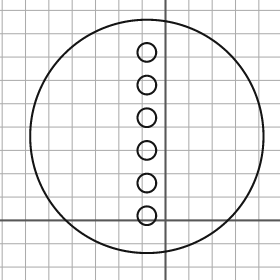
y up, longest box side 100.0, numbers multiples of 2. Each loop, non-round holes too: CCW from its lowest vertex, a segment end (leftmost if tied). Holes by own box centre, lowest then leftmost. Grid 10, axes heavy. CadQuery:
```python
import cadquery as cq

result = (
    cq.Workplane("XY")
    .moveTo(-8.0, 36.0)
    .circle(50.0)
    .moveTo(-8.0, 2.0)
    .circle(4.0)
    .moveTo(-8.0, 16.0)
    .circle(4.0)
    .moveTo(-8.0, 30.0)
    .circle(4.0)
    .moveTo(-8.0, 44.0)
    .circle(4.0)
    .moveTo(-8.0, 58.0)
    .circle(4.0)
    .moveTo(-8.0, 72.0)
    .circle(4.0)
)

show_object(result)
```